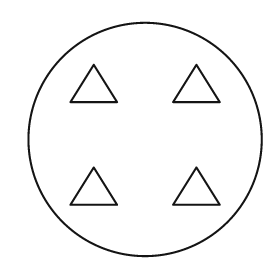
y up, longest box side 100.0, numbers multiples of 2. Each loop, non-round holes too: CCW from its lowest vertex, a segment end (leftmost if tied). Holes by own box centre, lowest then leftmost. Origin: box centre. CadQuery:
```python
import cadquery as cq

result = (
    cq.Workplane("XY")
    .moveTo(0.0, 0.0)
    .circle(50.0)
    .moveTo(-32.0, -28.0)
    .lineTo(-12.0, -28.0)
    .lineTo(-22.0, -12.0)
    .close()
    .moveTo(12.0, -28.0)
    .lineTo(32.0, -28.0)
    .lineTo(22.0, -12.0)
    .close()
    .moveTo(-32.0, 16.0)
    .lineTo(-12.0, 16.0)
    .lineTo(-22.0, 32.0)
    .close()
    .moveTo(12.0, 16.0)
    .lineTo(32.0, 16.0)
    .lineTo(22.0, 32.0)
    .close()
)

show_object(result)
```